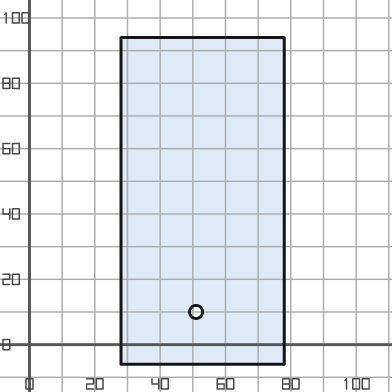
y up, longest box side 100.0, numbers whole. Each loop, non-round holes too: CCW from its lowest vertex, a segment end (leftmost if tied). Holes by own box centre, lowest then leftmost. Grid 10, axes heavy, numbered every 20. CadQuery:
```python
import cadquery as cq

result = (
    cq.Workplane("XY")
    .moveTo(28.0, -6.0)
    .lineTo(78.0, -6.0)
    .lineTo(78.0, 94.0)
    .lineTo(28.0, 94.0)
    .close()
    .moveTo(51.0, 10.0)
    .circle(2.0)
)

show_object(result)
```